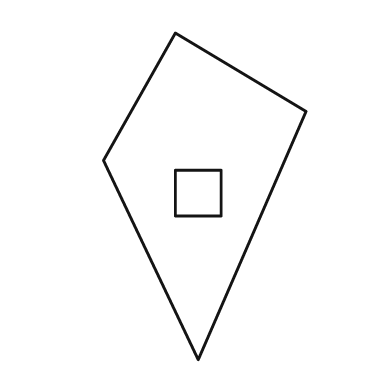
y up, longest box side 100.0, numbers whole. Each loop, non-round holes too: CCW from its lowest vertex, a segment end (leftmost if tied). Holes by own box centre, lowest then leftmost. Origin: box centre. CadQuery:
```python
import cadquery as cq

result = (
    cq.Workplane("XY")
    .moveTo(-2.0, -50.0)
    .lineTo(31.0, 26.0)
    .lineTo(-9.0, 50.0)
    .lineTo(-31.0, 11.0)
    .close()
    .moveTo(-9.0, -6.0)
    .lineTo(5.0, -6.0)
    .lineTo(5.0, 8.0)
    .lineTo(-9.0, 8.0)
    .close()
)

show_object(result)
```